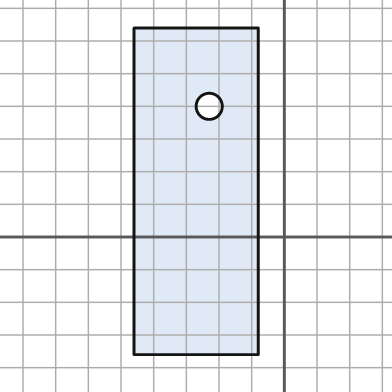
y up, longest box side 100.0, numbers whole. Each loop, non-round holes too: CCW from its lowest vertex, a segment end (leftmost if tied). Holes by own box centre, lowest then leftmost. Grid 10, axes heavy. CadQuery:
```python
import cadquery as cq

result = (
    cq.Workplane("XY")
    .moveTo(-46.0, -36.0)
    .lineTo(-8.0, -36.0)
    .lineTo(-8.0, 64.0)
    .lineTo(-46.0, 64.0)
    .close()
    .moveTo(-23.0, 40.0)
    .circle(4.0)
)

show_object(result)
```